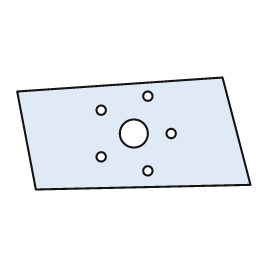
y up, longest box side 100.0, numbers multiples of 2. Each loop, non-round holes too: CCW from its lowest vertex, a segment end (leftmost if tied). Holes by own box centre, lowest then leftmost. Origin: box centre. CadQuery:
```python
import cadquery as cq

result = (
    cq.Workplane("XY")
    .moveTo(-42.0, -24.0)
    .lineTo(50.0, -22.0)
    .lineTo(38.0, 24.0)
    .lineTo(-50.0, 18.0)
    .close()
    .moveTo(6.0, -16.0)
    .circle(2.0)
    .moveTo(-14.0, -10.0)
    .circle(2.0)
    .moveTo(0.0, 0.0)
    .circle(6.0)
    .moveTo(16.0, 0.0)
    .circle(2.0)
    .moveTo(-14.0, 10.0)
    .circle(2.0)
    .moveTo(6.0, 16.0)
    .circle(2.0)
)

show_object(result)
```